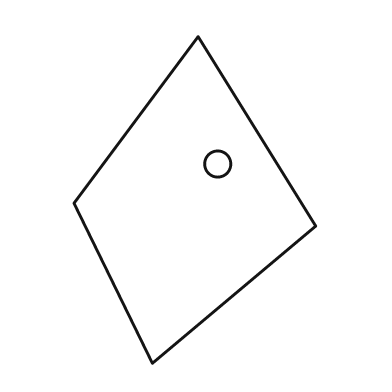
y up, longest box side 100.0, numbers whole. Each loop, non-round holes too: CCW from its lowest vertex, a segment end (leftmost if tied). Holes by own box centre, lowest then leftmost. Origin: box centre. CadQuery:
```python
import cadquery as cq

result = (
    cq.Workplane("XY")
    .moveTo(-13.0, -50.0)
    .lineTo(37.0, -8.0)
    .lineTo(1.0, 50.0)
    .lineTo(-37.0, -1.0)
    .close()
    .moveTo(7.0, 11.0)
    .circle(4.0)
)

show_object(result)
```